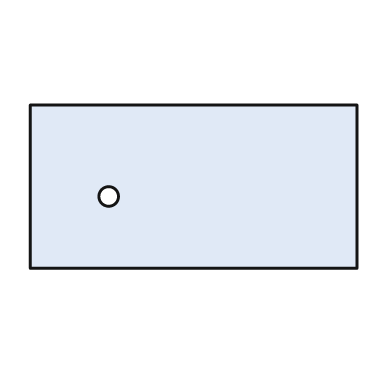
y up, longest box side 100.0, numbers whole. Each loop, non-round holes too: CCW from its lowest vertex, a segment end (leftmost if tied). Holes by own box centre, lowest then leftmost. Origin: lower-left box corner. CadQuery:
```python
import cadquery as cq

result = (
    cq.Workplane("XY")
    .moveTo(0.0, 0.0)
    .lineTo(100.0, 0.0)
    .lineTo(100.0, 50.0)
    .lineTo(0.0, 50.0)
    .close()
    .moveTo(24.0, 22.0)
    .circle(3.0)
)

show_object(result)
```